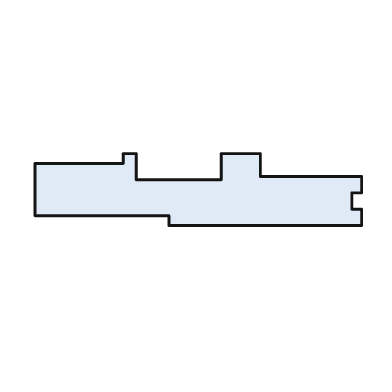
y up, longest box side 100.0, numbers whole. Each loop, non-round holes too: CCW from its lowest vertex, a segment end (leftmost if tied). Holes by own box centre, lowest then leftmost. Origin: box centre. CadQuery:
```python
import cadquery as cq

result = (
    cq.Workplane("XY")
    .moveTo(-9.0, -11.0)
    .lineTo(50.0, -11.0)
    .lineTo(50.0, -6.0)
    .lineTo(47.0, -6.0)
    .lineTo(47.0, -1.0)
    .lineTo(50.0, -1.0)
    .lineTo(50.0, 4.0)
    .lineTo(19.0, 4.0)
    .lineTo(19.0, 11.0)
    .lineTo(7.0, 11.0)
    .lineTo(7.0, 3.0)
    .lineTo(-19.0, 3.0)
    .lineTo(-19.0, 11.0)
    .lineTo(-23.0, 11.0)
    .lineTo(-23.0, 8.0)
    .lineTo(-50.0, 8.0)
    .lineTo(-50.0, -8.0)
    .lineTo(-9.0, -8.0)
    .close()
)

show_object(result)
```